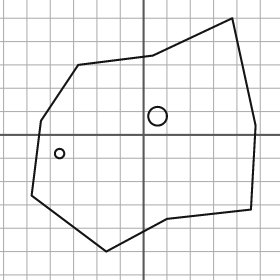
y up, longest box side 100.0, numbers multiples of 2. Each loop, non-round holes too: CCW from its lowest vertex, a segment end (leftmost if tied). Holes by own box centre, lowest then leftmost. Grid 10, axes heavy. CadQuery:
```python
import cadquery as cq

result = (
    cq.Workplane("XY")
    .moveTo(-16.0, -50.0)
    .lineTo(10.0, -36.0)
    .lineTo(46.0, -32.0)
    .lineTo(48.0, 4.0)
    .lineTo(38.0, 50.0)
    .lineTo(4.0, 34.0)
    .lineTo(-28.0, 30.0)
    .lineTo(-44.0, 6.0)
    .lineTo(-48.0, -26.0)
    .close()
    .moveTo(-36.0, -8.0)
    .circle(2.0)
    .moveTo(6.0, 8.0)
    .circle(4.0)
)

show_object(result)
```